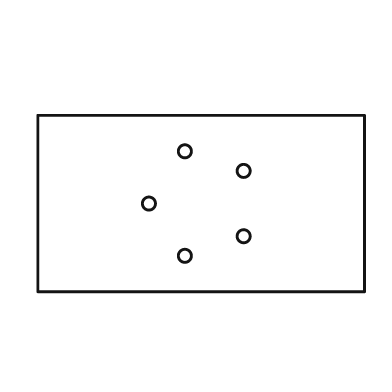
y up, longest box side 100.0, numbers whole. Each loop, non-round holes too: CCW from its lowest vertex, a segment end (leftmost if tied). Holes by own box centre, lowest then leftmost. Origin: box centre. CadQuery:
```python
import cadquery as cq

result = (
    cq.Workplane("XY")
    .moveTo(-50.0, -27.0)
    .lineTo(50.0, -27.0)
    .lineTo(50.0, 27.0)
    .lineTo(-50.0, 27.0)
    .close()
    .moveTo(-5.0, -16.0)
    .circle(2.0)
    .moveTo(13.0, -10.0)
    .circle(2.0)
    .moveTo(-16.0, 0.0)
    .circle(2.0)
    .moveTo(13.0, 10.0)
    .circle(2.0)
    .moveTo(-5.0, 16.0)
    .circle(2.0)
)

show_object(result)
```